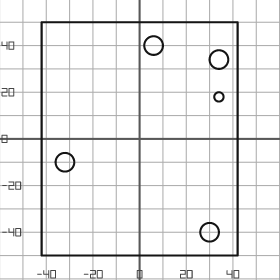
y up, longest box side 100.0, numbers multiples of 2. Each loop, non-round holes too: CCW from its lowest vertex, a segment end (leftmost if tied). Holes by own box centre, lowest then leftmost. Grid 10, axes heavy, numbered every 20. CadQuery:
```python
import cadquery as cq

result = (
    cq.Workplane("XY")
    .moveTo(-42.0, -50.0)
    .lineTo(42.0, -50.0)
    .lineTo(42.0, 50.0)
    .lineTo(-42.0, 50.0)
    .close()
    .moveTo(30.0, -40.0)
    .circle(4.0)
    .moveTo(-32.0, -10.0)
    .circle(4.0)
    .moveTo(34.0, 18.0)
    .circle(2.0)
    .moveTo(34.0, 34.0)
    .circle(4.0)
    .moveTo(6.0, 40.0)
    .circle(4.0)
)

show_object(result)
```